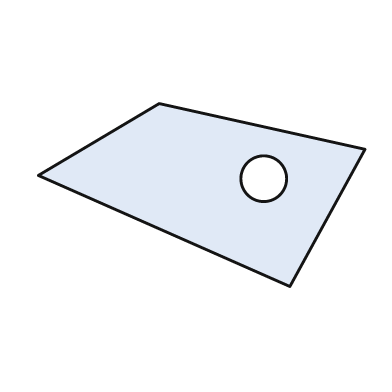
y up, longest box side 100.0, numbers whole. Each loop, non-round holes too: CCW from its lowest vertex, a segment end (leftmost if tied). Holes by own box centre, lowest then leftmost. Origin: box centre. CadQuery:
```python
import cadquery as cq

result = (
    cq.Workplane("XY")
    .moveTo(27.0, -28.0)
    .lineTo(50.0, 14.0)
    .lineTo(-13.0, 28.0)
    .lineTo(-50.0, 6.0)
    .close()
    .moveTo(19.0, 5.0)
    .circle(7.0)
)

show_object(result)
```